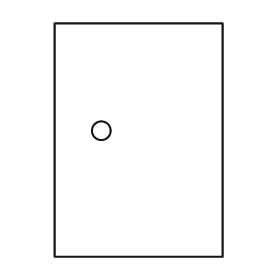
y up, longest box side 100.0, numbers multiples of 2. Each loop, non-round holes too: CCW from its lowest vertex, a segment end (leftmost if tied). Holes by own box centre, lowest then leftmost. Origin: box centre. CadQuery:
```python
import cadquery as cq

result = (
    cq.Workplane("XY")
    .moveTo(-36.0, -50.0)
    .lineTo(36.0, -50.0)
    .lineTo(36.0, 50.0)
    .lineTo(-36.0, 50.0)
    .close()
    .moveTo(-16.0, 4.0)
    .circle(4.0)
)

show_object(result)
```